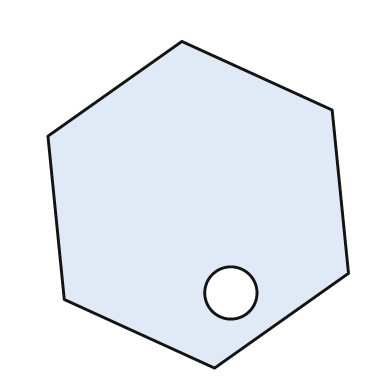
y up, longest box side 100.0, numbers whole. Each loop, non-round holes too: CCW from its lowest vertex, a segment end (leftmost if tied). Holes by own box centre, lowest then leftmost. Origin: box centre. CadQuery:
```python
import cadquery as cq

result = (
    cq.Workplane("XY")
    .moveTo(5.0, -50.0)
    .lineTo(46.0, -21.0)
    .lineTo(41.0, 29.0)
    .lineTo(-5.0, 50.0)
    .lineTo(-46.0, 21.0)
    .lineTo(-41.0, -29.0)
    .close()
    .moveTo(10.0, -27.0)
    .circle(8.0)
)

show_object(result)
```